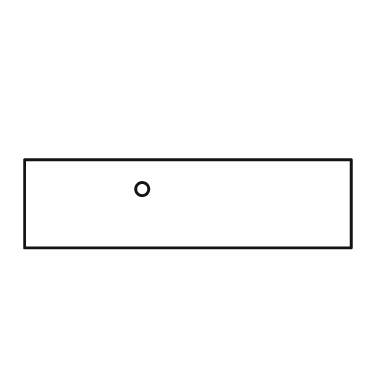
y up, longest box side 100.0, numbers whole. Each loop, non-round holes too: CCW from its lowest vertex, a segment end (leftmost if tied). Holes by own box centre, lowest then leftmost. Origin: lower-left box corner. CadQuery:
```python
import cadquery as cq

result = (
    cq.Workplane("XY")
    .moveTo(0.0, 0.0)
    .lineTo(100.0, 0.0)
    .lineTo(100.0, 27.0)
    .lineTo(0.0, 27.0)
    .close()
    .moveTo(36.0, 18.0)
    .circle(2.0)
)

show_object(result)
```